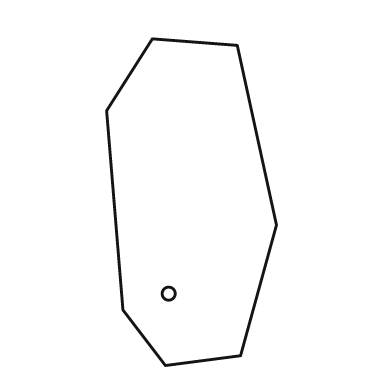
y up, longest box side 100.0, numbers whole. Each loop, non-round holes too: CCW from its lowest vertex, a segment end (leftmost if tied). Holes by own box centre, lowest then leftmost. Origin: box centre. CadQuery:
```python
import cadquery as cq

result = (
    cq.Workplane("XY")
    .moveTo(-8.0, -50.0)
    .lineTo(15.0, -47.0)
    .lineTo(26.0, -7.0)
    .lineTo(14.0, 48.0)
    .lineTo(-12.0, 50.0)
    .lineTo(-26.0, 28.0)
    .lineTo(-21.0, -33.0)
    .close()
    .moveTo(-7.0, -28.0)
    .circle(2.0)
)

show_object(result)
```